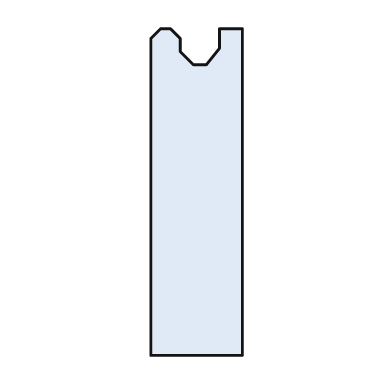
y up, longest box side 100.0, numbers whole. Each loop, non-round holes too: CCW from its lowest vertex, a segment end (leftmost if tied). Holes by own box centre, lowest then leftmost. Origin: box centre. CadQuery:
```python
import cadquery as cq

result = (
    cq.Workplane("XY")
    .moveTo(-14.0, -50.0)
    .lineTo(14.0, -50.0)
    .lineTo(14.0, 50.0)
    .lineTo(7.0, 50.0)
    .lineTo(7.0, 44.0)
    .lineTo(3.0, 39.0)
    .lineTo(-1.0, 39.0)
    .lineTo(-5.0, 43.0)
    .lineTo(-5.0, 47.0)
    .lineTo(-8.0, 50.0)
    .lineTo(-11.0, 50.0)
    .lineTo(-14.0, 47.0)
    .close()
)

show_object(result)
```